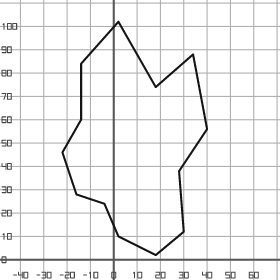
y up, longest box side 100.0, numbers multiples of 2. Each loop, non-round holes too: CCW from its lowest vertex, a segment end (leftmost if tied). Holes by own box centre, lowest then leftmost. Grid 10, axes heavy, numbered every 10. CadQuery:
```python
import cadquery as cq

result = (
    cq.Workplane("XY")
    .moveTo(18.0, 2.0)
    .lineTo(30.0, 12.0)
    .lineTo(28.0, 38.0)
    .lineTo(40.0, 56.0)
    .lineTo(34.0, 88.0)
    .lineTo(18.0, 74.0)
    .lineTo(2.0, 102.0)
    .lineTo(-14.0, 84.0)
    .lineTo(-14.0, 60.0)
    .lineTo(-22.0, 46.0)
    .lineTo(-16.0, 28.0)
    .lineTo(-4.0, 24.0)
    .lineTo(2.0, 10.0)
    .close()
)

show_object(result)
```